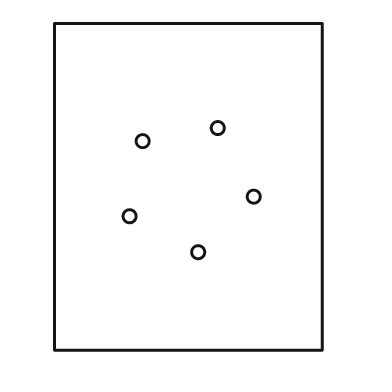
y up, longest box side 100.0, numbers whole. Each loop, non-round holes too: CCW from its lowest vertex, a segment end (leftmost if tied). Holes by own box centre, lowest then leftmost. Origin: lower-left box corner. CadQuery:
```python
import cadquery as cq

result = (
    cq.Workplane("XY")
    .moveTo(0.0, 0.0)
    .lineTo(82.0, 0.0)
    .lineTo(82.0, 100.0)
    .lineTo(0.0, 100.0)
    .close()
    .moveTo(44.0, 30.0)
    .circle(2.0)
    .moveTo(23.0, 41.0)
    .circle(2.0)
    .moveTo(61.0, 47.0)
    .circle(2.0)
    .moveTo(27.0, 64.0)
    .circle(2.0)
    .moveTo(50.0, 68.0)
    .circle(2.0)
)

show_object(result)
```